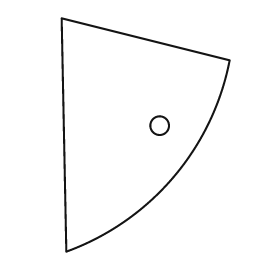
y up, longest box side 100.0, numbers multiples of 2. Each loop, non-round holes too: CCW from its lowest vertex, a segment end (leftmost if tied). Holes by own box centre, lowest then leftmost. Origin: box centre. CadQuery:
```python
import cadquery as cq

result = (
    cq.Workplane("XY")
    .moveTo(-34.0, -50.0)
    .threePointArc((12.0, -18.0), (36.0, 32.0))
    .lineTo(-36.0, 50.0)
    .close()
    .moveTo(6.0, 4.0)
    .circle(4.0)
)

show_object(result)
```